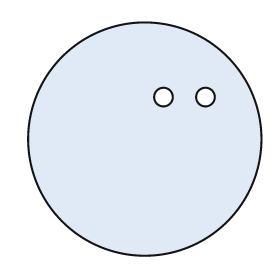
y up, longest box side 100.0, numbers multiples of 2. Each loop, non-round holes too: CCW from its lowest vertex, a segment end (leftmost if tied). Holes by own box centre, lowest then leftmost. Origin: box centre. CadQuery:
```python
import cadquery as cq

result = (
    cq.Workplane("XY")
    .moveTo(0.0, 0.0)
    .circle(50.0)
    .moveTo(8.0, 18.0)
    .circle(4.0)
    .moveTo(26.0, 18.0)
    .circle(4.0)
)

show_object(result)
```